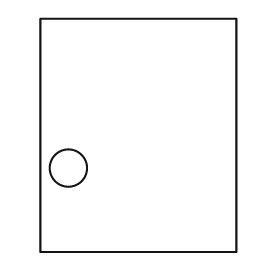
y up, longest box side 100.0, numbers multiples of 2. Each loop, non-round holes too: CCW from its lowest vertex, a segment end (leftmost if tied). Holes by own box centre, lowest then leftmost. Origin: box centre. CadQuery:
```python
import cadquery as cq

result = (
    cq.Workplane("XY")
    .moveTo(-42.0, -50.0)
    .lineTo(42.0, -50.0)
    .lineTo(42.0, 50.0)
    .lineTo(-42.0, 50.0)
    .close()
    .moveTo(-30.0, -14.0)
    .circle(8.0)
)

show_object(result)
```